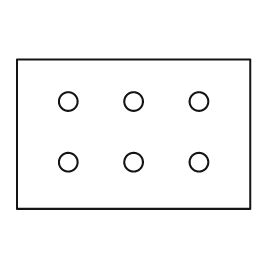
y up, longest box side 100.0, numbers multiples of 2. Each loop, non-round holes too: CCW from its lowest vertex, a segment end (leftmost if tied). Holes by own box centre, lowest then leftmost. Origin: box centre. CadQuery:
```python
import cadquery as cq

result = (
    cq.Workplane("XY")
    .moveTo(-50.0, -32.0)
    .lineTo(50.0, -32.0)
    .lineTo(50.0, 32.0)
    .lineTo(-50.0, 32.0)
    .close()
    .moveTo(-28.0, -12.0)
    .circle(4.0)
    .moveTo(0.0, -12.0)
    .circle(4.0)
    .moveTo(28.0, -12.0)
    .circle(4.0)
    .moveTo(-28.0, 14.0)
    .circle(4.0)
    .moveTo(0.0, 14.0)
    .circle(4.0)
    .moveTo(28.0, 14.0)
    .circle(4.0)
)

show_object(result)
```